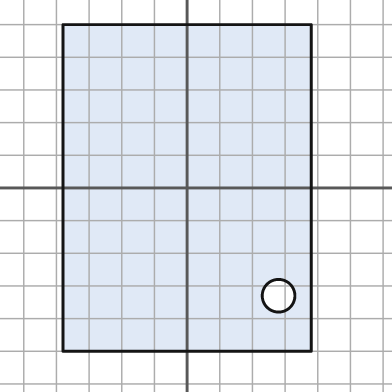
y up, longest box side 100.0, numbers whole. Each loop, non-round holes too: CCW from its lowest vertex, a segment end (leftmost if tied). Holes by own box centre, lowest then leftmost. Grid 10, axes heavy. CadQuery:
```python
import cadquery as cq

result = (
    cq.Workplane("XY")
    .moveTo(-38.0, -50.0)
    .lineTo(38.0, -50.0)
    .lineTo(38.0, 50.0)
    .lineTo(-38.0, 50.0)
    .close()
    .moveTo(28.0, -33.0)
    .circle(5.0)
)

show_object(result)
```